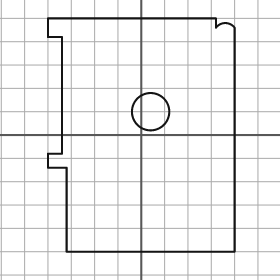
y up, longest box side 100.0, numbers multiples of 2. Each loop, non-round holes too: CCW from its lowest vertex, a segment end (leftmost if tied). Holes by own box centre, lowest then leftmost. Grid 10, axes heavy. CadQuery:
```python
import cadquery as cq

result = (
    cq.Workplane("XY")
    .moveTo(-32.0, -50.0)
    .lineTo(40.0, -50.0)
    .lineTo(40.0, 46.0)
    .threePointArc((36.0, 48.0), (32.0, 46.0))
    .lineTo(32.0, 50.0)
    .lineTo(-40.0, 50.0)
    .lineTo(-40.0, 42.0)
    .lineTo(-34.0, 42.0)
    .lineTo(-34.0, -8.0)
    .lineTo(-40.0, -8.0)
    .lineTo(-40.0, -14.0)
    .lineTo(-32.0, -14.0)
    .close()
    .moveTo(4.0, 10.0)
    .circle(8.0)
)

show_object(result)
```